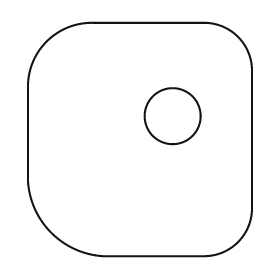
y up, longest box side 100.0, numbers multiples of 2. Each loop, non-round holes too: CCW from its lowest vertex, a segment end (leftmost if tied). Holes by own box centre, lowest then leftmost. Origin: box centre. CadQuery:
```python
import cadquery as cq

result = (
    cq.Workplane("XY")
    .moveTo(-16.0, -50.0)
    .lineTo(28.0, -50.0)
    .threePointArc((42.0, -44.0), (48.0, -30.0))
    .lineTo(48.0, 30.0)
    .threePointArc((42.0, 44.0), (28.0, 50.0))
    .lineTo(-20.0, 50.0)
    .threePointArc((-40.0, 42.0), (-48.0, 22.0))
    .lineTo(-48.0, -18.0)
    .threePointArc((-38.0, -40.0), (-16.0, -50.0))
    .close()
    .moveTo(14.0, 10.0)
    .circle(12.0)
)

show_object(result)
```